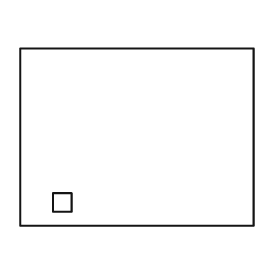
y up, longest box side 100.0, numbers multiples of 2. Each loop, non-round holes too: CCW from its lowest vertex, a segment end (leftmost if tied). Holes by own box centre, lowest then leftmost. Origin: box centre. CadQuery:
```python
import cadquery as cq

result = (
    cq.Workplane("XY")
    .moveTo(-50.0, -38.0)
    .lineTo(50.0, -38.0)
    .lineTo(50.0, 38.0)
    .lineTo(-50.0, 38.0)
    .close()
    .moveTo(-36.0, -32.0)
    .lineTo(-28.0, -32.0)
    .lineTo(-28.0, -24.0)
    .lineTo(-36.0, -24.0)
    .close()
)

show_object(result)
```